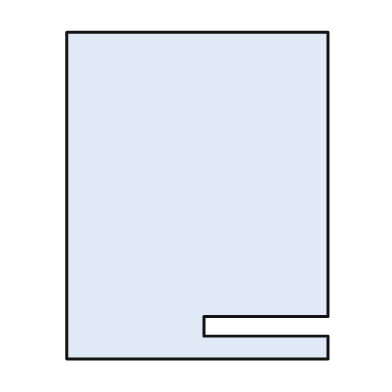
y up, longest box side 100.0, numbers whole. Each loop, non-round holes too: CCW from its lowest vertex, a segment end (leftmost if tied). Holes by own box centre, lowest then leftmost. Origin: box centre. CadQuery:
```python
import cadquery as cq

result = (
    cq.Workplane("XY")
    .moveTo(-40.0, -50.0)
    .lineTo(40.0, -50.0)
    .lineTo(40.0, -43.0)
    .lineTo(2.0, -43.0)
    .lineTo(2.0, -37.0)
    .lineTo(40.0, -37.0)
    .lineTo(40.0, 50.0)
    .lineTo(-40.0, 50.0)
    .close()
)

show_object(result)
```